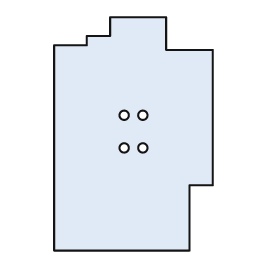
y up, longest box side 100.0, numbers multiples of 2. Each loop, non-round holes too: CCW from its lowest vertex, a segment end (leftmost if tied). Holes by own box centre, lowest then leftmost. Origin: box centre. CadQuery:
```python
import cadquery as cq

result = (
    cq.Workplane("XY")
    .moveTo(-34.0, -50.0)
    .lineTo(24.0, -50.0)
    .lineTo(24.0, -22.0)
    .lineTo(34.0, -22.0)
    .lineTo(34.0, 36.0)
    .lineTo(14.0, 36.0)
    .lineTo(14.0, 50.0)
    .lineTo(-10.0, 50.0)
    .lineTo(-10.0, 42.0)
    .lineTo(-20.0, 42.0)
    .lineTo(-20.0, 38.0)
    .lineTo(-34.0, 38.0)
    .close()
    .moveTo(-4.0, -6.0)
    .circle(2.0)
    .moveTo(4.0, -6.0)
    .circle(2.0)
    .moveTo(-4.0, 8.0)
    .circle(2.0)
    .moveTo(4.0, 8.0)
    .circle(2.0)
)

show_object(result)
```